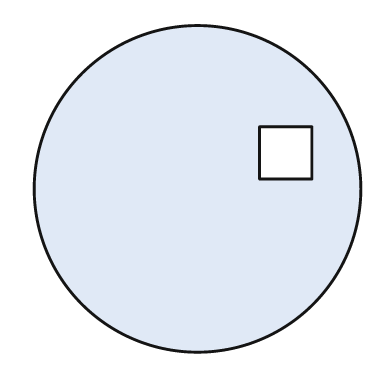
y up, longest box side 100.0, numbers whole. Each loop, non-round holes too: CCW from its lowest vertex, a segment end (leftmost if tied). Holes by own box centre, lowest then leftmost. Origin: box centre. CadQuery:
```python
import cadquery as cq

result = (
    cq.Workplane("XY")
    .moveTo(0.0, 0.0)
    .circle(50.0)
    .moveTo(19.0, 3.0)
    .lineTo(35.0, 3.0)
    .lineTo(35.0, 19.0)
    .lineTo(19.0, 19.0)
    .close()
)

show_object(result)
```